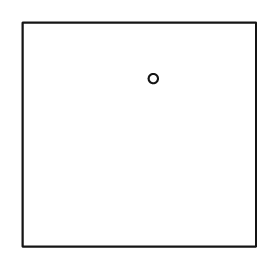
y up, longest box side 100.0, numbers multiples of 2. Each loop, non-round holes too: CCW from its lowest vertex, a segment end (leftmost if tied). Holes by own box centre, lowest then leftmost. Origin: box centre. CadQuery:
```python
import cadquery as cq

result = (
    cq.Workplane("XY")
    .moveTo(-50.0, -48.0)
    .lineTo(50.0, -48.0)
    .lineTo(50.0, 48.0)
    .lineTo(-50.0, 48.0)
    .close()
    .moveTo(6.0, 24.0)
    .circle(2.0)
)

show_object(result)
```